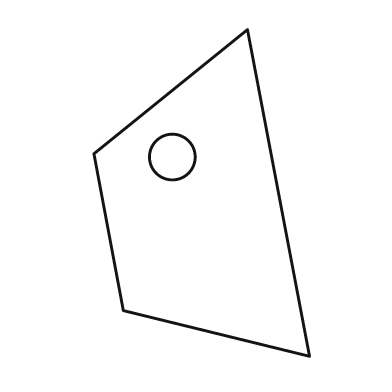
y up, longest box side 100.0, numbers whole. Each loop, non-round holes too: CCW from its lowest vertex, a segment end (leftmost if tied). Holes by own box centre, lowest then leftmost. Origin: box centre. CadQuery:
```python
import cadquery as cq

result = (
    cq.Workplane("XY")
    .moveTo(33.0, -50.0)
    .lineTo(14.0, 50.0)
    .lineTo(-33.0, 12.0)
    .lineTo(-24.0, -36.0)
    .close()
    .moveTo(-9.0, 11.0)
    .circle(7.0)
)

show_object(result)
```